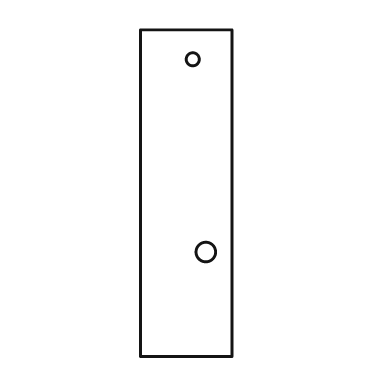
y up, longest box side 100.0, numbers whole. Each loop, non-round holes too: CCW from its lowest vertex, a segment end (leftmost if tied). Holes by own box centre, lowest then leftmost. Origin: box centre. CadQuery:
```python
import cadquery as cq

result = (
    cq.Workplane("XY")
    .moveTo(-14.0, -50.0)
    .lineTo(14.0, -50.0)
    .lineTo(14.0, 50.0)
    .lineTo(-14.0, 50.0)
    .close()
    .moveTo(6.0, -18.0)
    .circle(3.0)
    .moveTo(2.0, 41.0)
    .circle(2.0)
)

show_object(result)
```